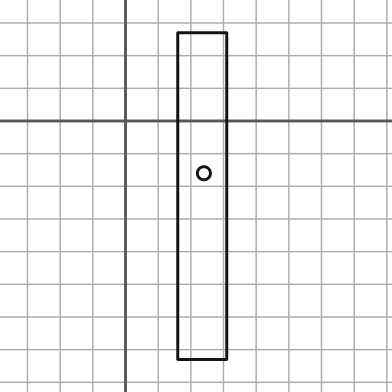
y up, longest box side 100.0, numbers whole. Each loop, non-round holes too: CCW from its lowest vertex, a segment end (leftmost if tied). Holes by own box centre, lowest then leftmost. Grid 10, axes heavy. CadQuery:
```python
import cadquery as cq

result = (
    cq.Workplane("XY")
    .moveTo(16.0, -73.0)
    .lineTo(31.0, -73.0)
    .lineTo(31.0, 27.0)
    .lineTo(16.0, 27.0)
    .close()
    .moveTo(24.0, -16.0)
    .circle(2.0)
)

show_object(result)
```